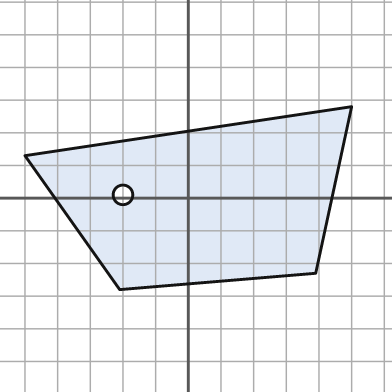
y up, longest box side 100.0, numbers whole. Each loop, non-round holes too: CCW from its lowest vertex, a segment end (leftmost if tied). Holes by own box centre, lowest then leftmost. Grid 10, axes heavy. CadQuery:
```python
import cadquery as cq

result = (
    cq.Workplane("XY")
    .moveTo(-21.0, -28.0)
    .lineTo(39.0, -23.0)
    .lineTo(50.0, 28.0)
    .lineTo(-50.0, 13.0)
    .close()
    .moveTo(-20.0, 1.0)
    .circle(3.0)
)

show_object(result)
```